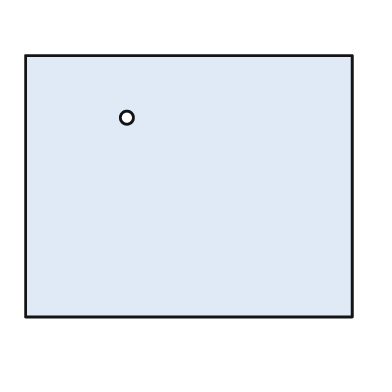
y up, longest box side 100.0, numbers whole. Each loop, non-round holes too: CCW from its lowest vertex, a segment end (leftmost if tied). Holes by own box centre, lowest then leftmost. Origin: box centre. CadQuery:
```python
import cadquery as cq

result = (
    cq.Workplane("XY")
    .moveTo(-50.0, -40.0)
    .lineTo(50.0, -40.0)
    .lineTo(50.0, 40.0)
    .lineTo(-50.0, 40.0)
    .close()
    .moveTo(-19.0, 21.0)
    .circle(2.0)
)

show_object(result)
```